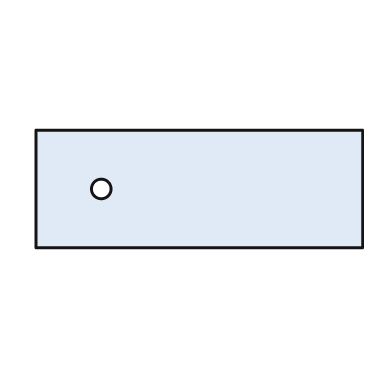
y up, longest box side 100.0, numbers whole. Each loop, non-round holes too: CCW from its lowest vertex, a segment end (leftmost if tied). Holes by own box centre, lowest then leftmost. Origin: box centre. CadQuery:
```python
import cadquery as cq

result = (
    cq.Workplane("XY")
    .moveTo(-50.0, -18.0)
    .lineTo(50.0, -18.0)
    .lineTo(50.0, 18.0)
    .lineTo(-50.0, 18.0)
    .close()
    .moveTo(-30.0, 0.0)
    .circle(3.0)
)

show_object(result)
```